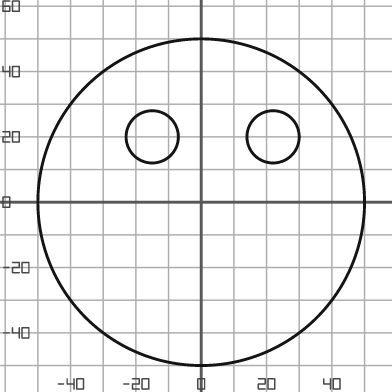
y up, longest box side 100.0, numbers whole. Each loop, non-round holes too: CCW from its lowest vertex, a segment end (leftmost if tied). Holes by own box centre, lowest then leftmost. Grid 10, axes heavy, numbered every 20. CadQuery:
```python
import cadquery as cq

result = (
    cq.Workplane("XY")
    .moveTo(0.0, 0.0)
    .circle(50.0)
    .moveTo(-15.0, 20.0)
    .circle(8.0)
    .moveTo(22.0, 20.0)
    .circle(8.0)
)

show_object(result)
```